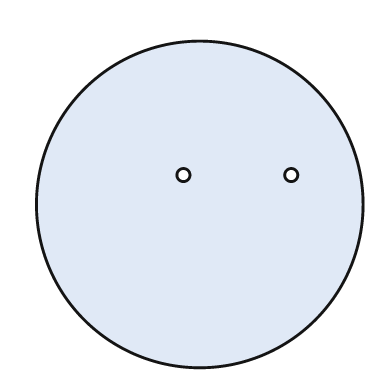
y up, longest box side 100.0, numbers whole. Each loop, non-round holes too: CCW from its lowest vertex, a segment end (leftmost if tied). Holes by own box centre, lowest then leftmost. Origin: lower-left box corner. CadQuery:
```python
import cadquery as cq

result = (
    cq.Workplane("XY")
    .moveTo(50.0, 50.0)
    .circle(50.0)
    .moveTo(45.0, 59.0)
    .circle(2.0)
    .moveTo(78.0, 59.0)
    .circle(2.0)
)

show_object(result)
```